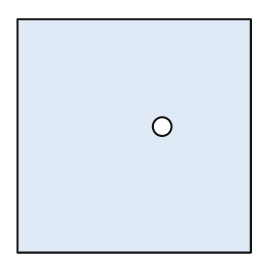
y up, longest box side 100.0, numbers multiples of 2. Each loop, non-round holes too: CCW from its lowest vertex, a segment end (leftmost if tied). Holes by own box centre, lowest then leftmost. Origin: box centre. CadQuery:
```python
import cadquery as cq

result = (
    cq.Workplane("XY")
    .moveTo(-50.0, -50.0)
    .lineTo(50.0, -50.0)
    .lineTo(50.0, 50.0)
    .lineTo(-50.0, 50.0)
    .close()
    .moveTo(12.0, 4.0)
    .circle(4.0)
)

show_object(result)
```